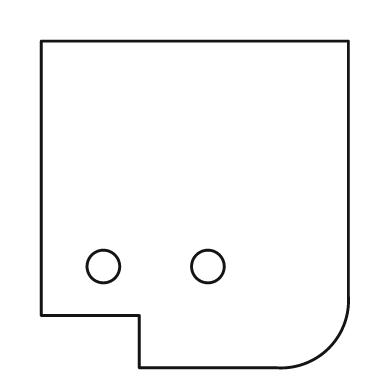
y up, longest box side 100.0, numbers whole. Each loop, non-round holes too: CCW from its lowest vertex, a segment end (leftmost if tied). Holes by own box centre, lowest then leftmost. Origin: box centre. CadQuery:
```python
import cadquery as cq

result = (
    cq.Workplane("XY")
    .moveTo(-17.0, -50.0)
    .lineTo(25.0, -50.0)
    .threePointArc((41.0, -44.0), (47.0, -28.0))
    .lineTo(47.0, 50.0)
    .lineTo(-47.0, 50.0)
    .lineTo(-47.0, -34.0)
    .lineTo(-17.0, -34.0)
    .close()
    .moveTo(-28.0, -19.0)
    .circle(5.0)
    .moveTo(4.0, -19.0)
    .circle(5.0)
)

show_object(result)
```